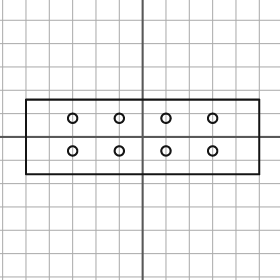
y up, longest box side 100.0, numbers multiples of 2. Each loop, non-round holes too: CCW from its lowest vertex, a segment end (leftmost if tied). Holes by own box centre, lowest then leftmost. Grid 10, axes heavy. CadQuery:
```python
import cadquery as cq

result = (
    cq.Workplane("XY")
    .moveTo(-50.0, -16.0)
    .lineTo(50.0, -16.0)
    .lineTo(50.0, 16.0)
    .lineTo(-50.0, 16.0)
    .close()
    .moveTo(-30.0, -6.0)
    .circle(2.0)
    .moveTo(-10.0, -6.0)
    .circle(2.0)
    .moveTo(10.0, -6.0)
    .circle(2.0)
    .moveTo(30.0, -6.0)
    .circle(2.0)
    .moveTo(-30.0, 8.0)
    .circle(2.0)
    .moveTo(-10.0, 8.0)
    .circle(2.0)
    .moveTo(10.0, 8.0)
    .circle(2.0)
    .moveTo(30.0, 8.0)
    .circle(2.0)
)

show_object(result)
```